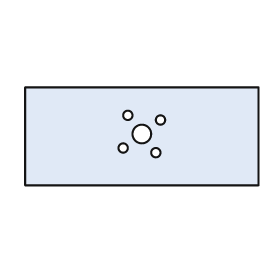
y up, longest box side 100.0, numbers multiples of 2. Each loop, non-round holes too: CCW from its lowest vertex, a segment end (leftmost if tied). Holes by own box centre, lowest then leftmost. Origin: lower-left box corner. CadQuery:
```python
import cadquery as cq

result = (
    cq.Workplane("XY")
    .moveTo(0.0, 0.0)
    .lineTo(100.0, 0.0)
    .lineTo(100.0, 42.0)
    .lineTo(0.0, 42.0)
    .close()
    .moveTo(56.0, 14.0)
    .circle(2.0)
    .moveTo(42.0, 16.0)
    .circle(2.0)
    .moveTo(50.0, 22.0)
    .circle(4.0)
    .moveTo(58.0, 28.0)
    .circle(2.0)
    .moveTo(44.0, 30.0)
    .circle(2.0)
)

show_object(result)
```